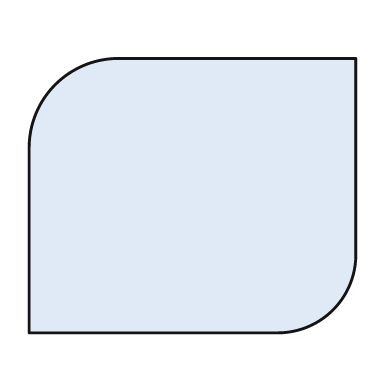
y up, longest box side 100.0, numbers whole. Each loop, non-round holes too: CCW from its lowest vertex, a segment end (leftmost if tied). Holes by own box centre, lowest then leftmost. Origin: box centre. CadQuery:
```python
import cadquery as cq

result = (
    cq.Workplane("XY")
    .moveTo(-50.0, -42.0)
    .lineTo(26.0, -42.0)
    .threePointArc((43.0, -35.0), (50.0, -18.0))
    .lineTo(50.0, 42.0)
    .lineTo(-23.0, 42.0)
    .threePointArc((-42.0, 34.0), (-50.0, 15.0))
    .close()
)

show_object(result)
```